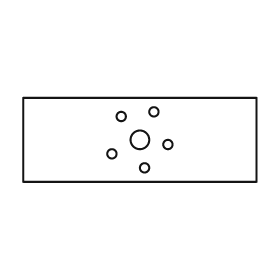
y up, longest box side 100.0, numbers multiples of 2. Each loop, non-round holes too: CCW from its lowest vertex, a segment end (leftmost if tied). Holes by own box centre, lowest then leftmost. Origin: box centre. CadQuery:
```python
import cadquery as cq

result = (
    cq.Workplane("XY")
    .moveTo(-50.0, -18.0)
    .lineTo(50.0, -18.0)
    .lineTo(50.0, 18.0)
    .lineTo(-50.0, 18.0)
    .close()
    .moveTo(2.0, -12.0)
    .circle(2.0)
    .moveTo(-12.0, -6.0)
    .circle(2.0)
    .moveTo(12.0, -2.0)
    .circle(2.0)
    .moveTo(0.0, 0.0)
    .circle(4.0)
    .moveTo(-8.0, 10.0)
    .circle(2.0)
    .moveTo(6.0, 12.0)
    .circle(2.0)
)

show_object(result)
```